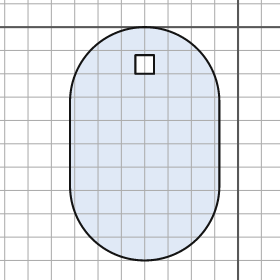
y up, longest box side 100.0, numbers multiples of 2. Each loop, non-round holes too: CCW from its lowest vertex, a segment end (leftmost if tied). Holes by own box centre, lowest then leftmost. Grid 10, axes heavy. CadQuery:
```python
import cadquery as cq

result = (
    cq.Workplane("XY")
    .moveTo(-72.0, -68.0)
    .threePointArc((-40.0, -100.0), (-8.0, -68.0))
    .lineTo(-8.0, -32.0)
    .threePointArc((-40.0, 0.0), (-72.0, -32.0))
    .close()
    .moveTo(-44.0, -20.0)
    .lineTo(-36.0, -20.0)
    .lineTo(-36.0, -12.0)
    .lineTo(-44.0, -12.0)
    .close()
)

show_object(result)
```